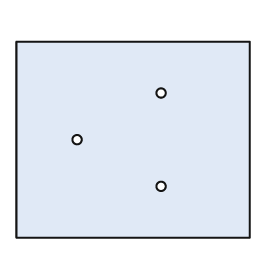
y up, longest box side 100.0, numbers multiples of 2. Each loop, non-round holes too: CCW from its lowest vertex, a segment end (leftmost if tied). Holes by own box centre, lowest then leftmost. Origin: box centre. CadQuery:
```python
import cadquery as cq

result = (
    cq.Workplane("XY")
    .moveTo(-50.0, -42.0)
    .lineTo(50.0, -42.0)
    .lineTo(50.0, 42.0)
    .lineTo(-50.0, 42.0)
    .close()
    .moveTo(12.0, -20.0)
    .circle(2.0)
    .moveTo(-24.0, 0.0)
    .circle(2.0)
    .moveTo(12.0, 20.0)
    .circle(2.0)
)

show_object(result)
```